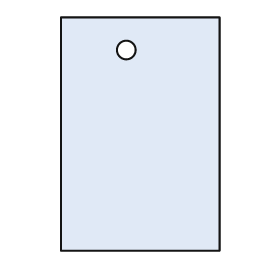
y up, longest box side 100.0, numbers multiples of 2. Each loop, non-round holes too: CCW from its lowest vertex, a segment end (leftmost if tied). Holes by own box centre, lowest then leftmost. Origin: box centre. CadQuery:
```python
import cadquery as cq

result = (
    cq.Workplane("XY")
    .moveTo(-34.0, -50.0)
    .lineTo(34.0, -50.0)
    .lineTo(34.0, 50.0)
    .lineTo(-34.0, 50.0)
    .close()
    .moveTo(-6.0, 36.0)
    .circle(4.0)
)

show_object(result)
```